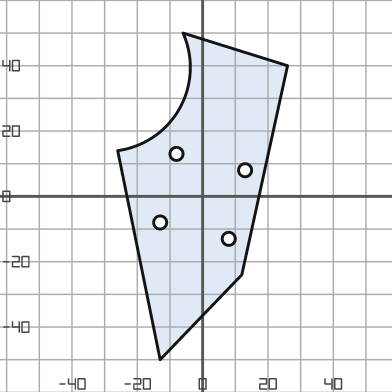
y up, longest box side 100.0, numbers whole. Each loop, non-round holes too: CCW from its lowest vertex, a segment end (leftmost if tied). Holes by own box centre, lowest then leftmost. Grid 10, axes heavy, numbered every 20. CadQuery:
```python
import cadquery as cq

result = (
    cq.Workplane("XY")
    .moveTo(-13.0, -50.0)
    .lineTo(12.0, -24.0)
    .lineTo(26.0, 40.0)
    .lineTo(-6.0, 50.0)
    .threePointArc((-7.0, 27.0), (-26.0, 14.0))
    .close()
    .moveTo(8.0, -13.0)
    .circle(2.0)
    .moveTo(-13.0, -8.0)
    .circle(2.0)
    .moveTo(13.0, 8.0)
    .circle(2.0)
    .moveTo(-8.0, 13.0)
    .circle(2.0)
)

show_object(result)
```